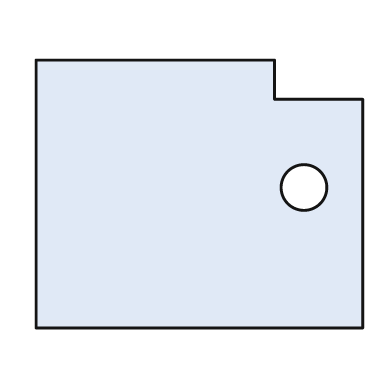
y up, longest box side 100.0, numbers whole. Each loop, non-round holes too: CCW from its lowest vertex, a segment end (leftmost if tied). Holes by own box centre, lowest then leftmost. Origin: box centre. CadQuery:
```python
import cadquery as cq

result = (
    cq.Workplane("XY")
    .moveTo(-50.0, -41.0)
    .lineTo(50.0, -41.0)
    .lineTo(50.0, 29.0)
    .lineTo(23.0, 29.0)
    .lineTo(23.0, 41.0)
    .lineTo(-50.0, 41.0)
    .close()
    .moveTo(32.0, 2.0)
    .circle(7.0)
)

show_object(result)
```